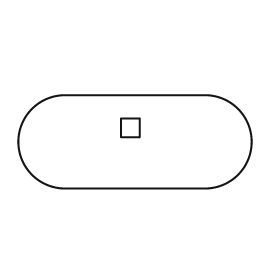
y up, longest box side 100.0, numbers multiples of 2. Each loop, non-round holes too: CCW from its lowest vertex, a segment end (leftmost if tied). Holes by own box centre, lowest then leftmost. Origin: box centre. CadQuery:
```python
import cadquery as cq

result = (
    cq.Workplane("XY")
    .moveTo(-30.0, -20.0)
    .lineTo(30.0, -20.0)
    .threePointArc((50.0, 0.0), (30.0, 20.0))
    .lineTo(-30.0, 20.0)
    .threePointArc((-50.0, 0.0), (-30.0, -20.0))
    .close()
    .moveTo(-6.0, 2.0)
    .lineTo(2.0, 2.0)
    .lineTo(2.0, 10.0)
    .lineTo(-6.0, 10.0)
    .close()
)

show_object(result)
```